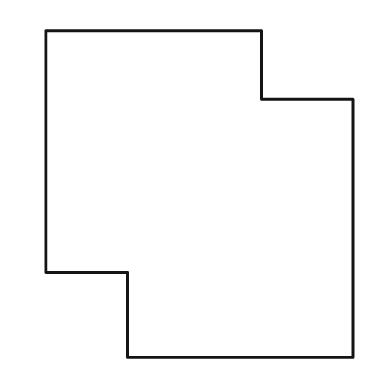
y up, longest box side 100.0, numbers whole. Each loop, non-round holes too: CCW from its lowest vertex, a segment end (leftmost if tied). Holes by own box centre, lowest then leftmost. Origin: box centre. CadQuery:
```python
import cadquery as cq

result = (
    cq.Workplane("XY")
    .moveTo(-22.0, -50.0)
    .lineTo(47.0, -50.0)
    .lineTo(47.0, 29.0)
    .lineTo(19.0, 29.0)
    .lineTo(19.0, 50.0)
    .lineTo(-47.0, 50.0)
    .lineTo(-47.0, -24.0)
    .lineTo(-22.0, -24.0)
    .close()
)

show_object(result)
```